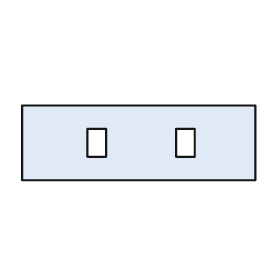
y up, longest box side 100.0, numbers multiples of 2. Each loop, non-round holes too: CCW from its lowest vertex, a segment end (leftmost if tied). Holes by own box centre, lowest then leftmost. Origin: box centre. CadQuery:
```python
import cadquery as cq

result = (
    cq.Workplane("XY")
    .moveTo(-50.0, -16.0)
    .lineTo(50.0, -16.0)
    .lineTo(50.0, 16.0)
    .lineTo(-50.0, 16.0)
    .close()
    .moveTo(-22.0, -6.0)
    .lineTo(-14.0, -6.0)
    .lineTo(-14.0, 6.0)
    .lineTo(-22.0, 6.0)
    .close()
    .moveTo(16.0, -6.0)
    .lineTo(24.0, -6.0)
    .lineTo(24.0, 6.0)
    .lineTo(16.0, 6.0)
    .close()
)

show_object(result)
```